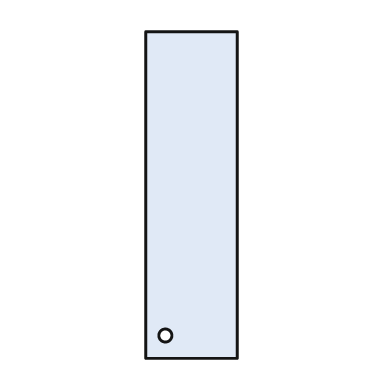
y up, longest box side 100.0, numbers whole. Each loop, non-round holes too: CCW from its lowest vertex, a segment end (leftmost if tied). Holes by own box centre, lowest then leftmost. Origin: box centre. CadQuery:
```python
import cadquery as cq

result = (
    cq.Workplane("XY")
    .moveTo(-14.0, -50.0)
    .lineTo(14.0, -50.0)
    .lineTo(14.0, 50.0)
    .lineTo(-14.0, 50.0)
    .close()
    .moveTo(-8.0, -43.0)
    .circle(2.0)
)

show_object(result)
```